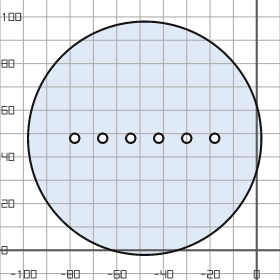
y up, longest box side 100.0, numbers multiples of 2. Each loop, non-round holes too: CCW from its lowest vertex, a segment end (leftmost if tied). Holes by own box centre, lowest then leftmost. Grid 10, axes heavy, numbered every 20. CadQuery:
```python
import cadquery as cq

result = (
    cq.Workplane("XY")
    .moveTo(-48.0, 48.0)
    .circle(50.0)
    .moveTo(-78.0, 48.0)
    .circle(2.0)
    .moveTo(-66.0, 48.0)
    .circle(2.0)
    .moveTo(-54.0, 48.0)
    .circle(2.0)
    .moveTo(-42.0, 48.0)
    .circle(2.0)
    .moveTo(-30.0, 48.0)
    .circle(2.0)
    .moveTo(-18.0, 48.0)
    .circle(2.0)
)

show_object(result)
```